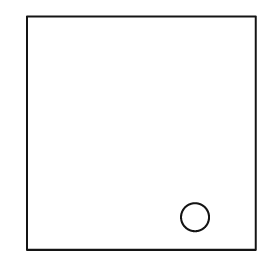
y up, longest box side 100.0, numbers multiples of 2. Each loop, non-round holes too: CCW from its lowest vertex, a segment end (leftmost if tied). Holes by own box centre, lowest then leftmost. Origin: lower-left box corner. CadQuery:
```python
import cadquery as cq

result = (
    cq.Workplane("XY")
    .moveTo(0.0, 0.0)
    .lineTo(98.0, 0.0)
    .lineTo(98.0, 100.0)
    .lineTo(0.0, 100.0)
    .close()
    .moveTo(72.0, 14.0)
    .circle(6.0)
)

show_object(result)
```